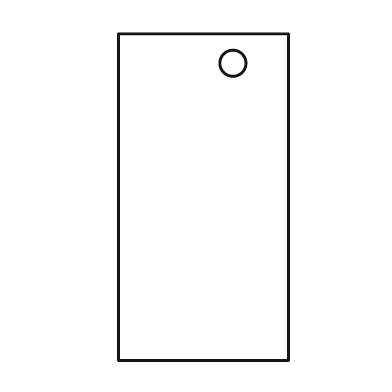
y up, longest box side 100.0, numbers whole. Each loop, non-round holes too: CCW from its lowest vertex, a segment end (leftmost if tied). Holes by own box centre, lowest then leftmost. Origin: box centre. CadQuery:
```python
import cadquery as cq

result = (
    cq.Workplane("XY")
    .moveTo(-26.0, -50.0)
    .lineTo(26.0, -50.0)
    .lineTo(26.0, 50.0)
    .lineTo(-26.0, 50.0)
    .close()
    .moveTo(9.0, 41.0)
    .circle(4.0)
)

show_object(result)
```